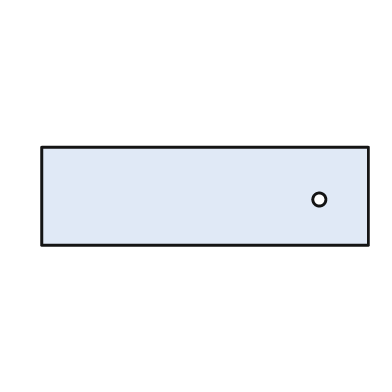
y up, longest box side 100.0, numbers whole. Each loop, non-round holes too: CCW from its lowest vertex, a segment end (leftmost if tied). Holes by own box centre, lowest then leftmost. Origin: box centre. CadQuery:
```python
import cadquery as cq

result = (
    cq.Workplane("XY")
    .moveTo(-50.0, -15.0)
    .lineTo(50.0, -15.0)
    .lineTo(50.0, 15.0)
    .lineTo(-50.0, 15.0)
    .close()
    .moveTo(35.0, -1.0)
    .circle(2.0)
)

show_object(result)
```